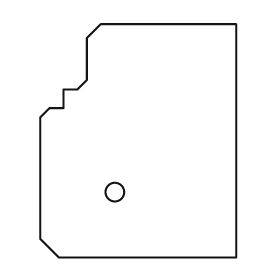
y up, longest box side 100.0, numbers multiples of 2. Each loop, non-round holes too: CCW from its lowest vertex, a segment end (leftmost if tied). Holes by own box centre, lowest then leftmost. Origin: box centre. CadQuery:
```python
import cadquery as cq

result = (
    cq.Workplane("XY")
    .moveTo(-34.0, -50.0)
    .lineTo(42.0, -50.0)
    .lineTo(42.0, 50.0)
    .lineTo(-16.0, 50.0)
    .lineTo(-22.0, 44.0)
    .lineTo(-22.0, 26.0)
    .lineTo(-26.0, 22.0)
    .lineTo(-32.0, 22.0)
    .lineTo(-32.0, 14.0)
    .lineTo(-38.0, 14.0)
    .lineTo(-42.0, 10.0)
    .lineTo(-42.0, -42.0)
    .close()
    .moveTo(-10.0, -22.0)
    .circle(4.0)
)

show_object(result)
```